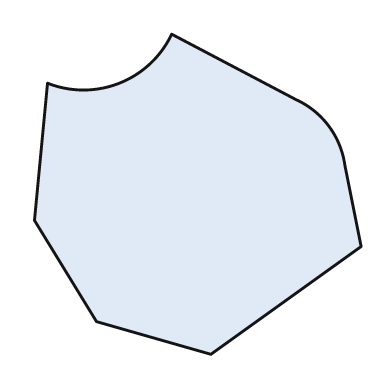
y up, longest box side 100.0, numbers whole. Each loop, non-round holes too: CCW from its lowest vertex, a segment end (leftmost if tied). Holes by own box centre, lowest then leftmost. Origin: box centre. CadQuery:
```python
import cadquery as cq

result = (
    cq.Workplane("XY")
    .moveTo(4.0, -49.0)
    .lineTo(50.0, -16.0)
    .lineTo(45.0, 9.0)
    .threePointArc((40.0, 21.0), (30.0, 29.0))
    .lineTo(-8.0, 49.0)
    .threePointArc((-24.0, 34.0), (-46.0, 34.0))
    .lineTo(-50.0, -8.0)
    .lineTo(-31.0, -39.0)
    .close()
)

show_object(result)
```